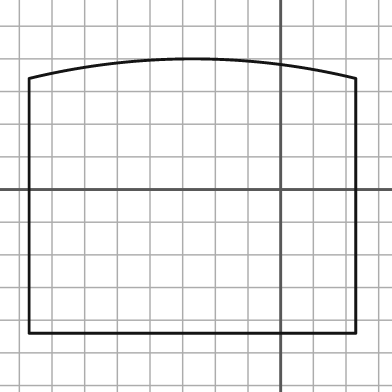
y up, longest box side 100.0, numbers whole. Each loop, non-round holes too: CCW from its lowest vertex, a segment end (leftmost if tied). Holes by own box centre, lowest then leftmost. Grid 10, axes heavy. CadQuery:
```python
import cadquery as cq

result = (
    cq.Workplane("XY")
    .moveTo(-77.0, -44.0)
    .lineTo(23.0, -44.0)
    .lineTo(23.0, 34.0)
    .threePointArc((-27.0, 40.0), (-77.0, 34.0))
    .close()
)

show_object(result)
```